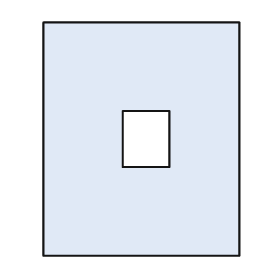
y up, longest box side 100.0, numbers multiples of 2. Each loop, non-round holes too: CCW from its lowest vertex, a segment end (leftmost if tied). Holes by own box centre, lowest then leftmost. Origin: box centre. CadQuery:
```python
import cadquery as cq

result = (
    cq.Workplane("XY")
    .moveTo(-42.0, -50.0)
    .lineTo(42.0, -50.0)
    .lineTo(42.0, 50.0)
    .lineTo(-42.0, 50.0)
    .close()
    .moveTo(-8.0, -12.0)
    .lineTo(12.0, -12.0)
    .lineTo(12.0, 12.0)
    .lineTo(-8.0, 12.0)
    .close()
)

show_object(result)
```